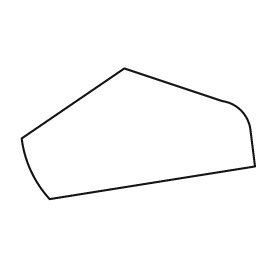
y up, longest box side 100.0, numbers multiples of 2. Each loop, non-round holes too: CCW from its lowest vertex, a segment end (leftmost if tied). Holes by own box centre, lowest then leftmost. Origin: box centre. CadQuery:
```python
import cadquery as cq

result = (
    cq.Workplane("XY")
    .moveTo(-38.0, -28.0)
    .lineTo(50.0, -14.0)
    .lineTo(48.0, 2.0)
    .threePointArc((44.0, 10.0), (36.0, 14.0))
    .lineTo(-6.0, 28.0)
    .lineTo(-50.0, -2.0)
    .threePointArc((-46.0, -16.0), (-38.0, -28.0))
    .close()
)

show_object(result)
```